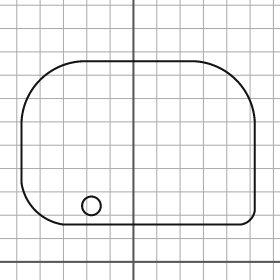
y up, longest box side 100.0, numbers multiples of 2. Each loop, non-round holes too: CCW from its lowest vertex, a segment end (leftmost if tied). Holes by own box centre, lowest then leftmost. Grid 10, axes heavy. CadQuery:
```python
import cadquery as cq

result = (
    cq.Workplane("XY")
    .moveTo(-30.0, 16.0)
    .lineTo(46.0, 16.0)
    .threePointArc((50.0, 18.0), (52.0, 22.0))
    .lineTo(52.0, 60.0)
    .threePointArc((44.0, 78.0), (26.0, 86.0))
    .lineTo(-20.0, 86.0)
    .threePointArc((-40.0, 78.0), (-48.0, 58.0))
    .lineTo(-48.0, 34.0)
    .threePointArc((-42.0, 22.0), (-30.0, 16.0))
    .close()
    .moveTo(-18.0, 24.0)
    .circle(4.0)
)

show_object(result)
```